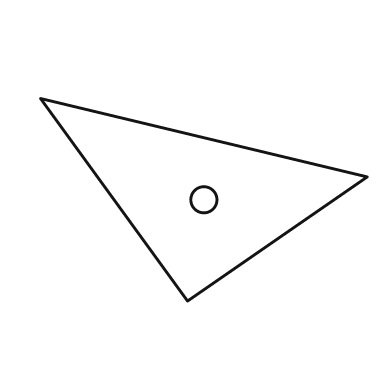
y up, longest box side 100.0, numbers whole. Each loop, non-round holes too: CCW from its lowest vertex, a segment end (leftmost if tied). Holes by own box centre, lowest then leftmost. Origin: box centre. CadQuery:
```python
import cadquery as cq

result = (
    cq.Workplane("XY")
    .moveTo(-5.0, -31.0)
    .lineTo(50.0, 7.0)
    .lineTo(-50.0, 31.0)
    .close()
    .moveTo(0.0, 0.0)
    .circle(4.0)
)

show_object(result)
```